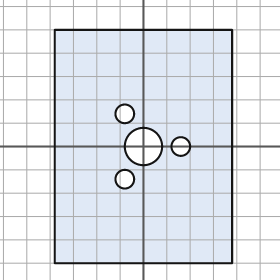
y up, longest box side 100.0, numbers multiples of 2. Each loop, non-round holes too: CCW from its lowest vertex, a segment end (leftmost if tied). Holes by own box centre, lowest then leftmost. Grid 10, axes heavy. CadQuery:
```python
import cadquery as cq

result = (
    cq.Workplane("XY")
    .moveTo(-38.0, -50.0)
    .lineTo(38.0, -50.0)
    .lineTo(38.0, 50.0)
    .lineTo(-38.0, 50.0)
    .close()
    .moveTo(-8.0, -14.0)
    .circle(4.0)
    .moveTo(0.0, 0.0)
    .circle(8.0)
    .moveTo(16.0, 0.0)
    .circle(4.0)
    .moveTo(-8.0, 14.0)
    .circle(4.0)
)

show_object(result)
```